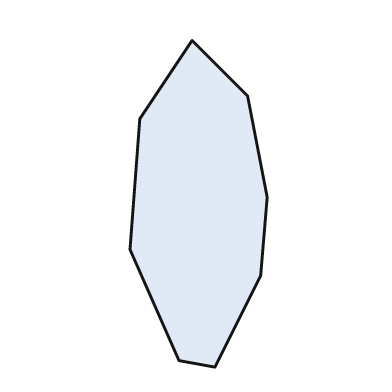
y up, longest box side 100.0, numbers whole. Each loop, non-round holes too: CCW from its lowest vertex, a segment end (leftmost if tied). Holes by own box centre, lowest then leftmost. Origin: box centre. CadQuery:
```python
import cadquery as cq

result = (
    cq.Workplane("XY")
    .moveTo(5.0, -50.0)
    .lineTo(19.0, -22.0)
    .lineTo(21.0, 2.0)
    .lineTo(15.0, 33.0)
    .lineTo(-2.0, 50.0)
    .lineTo(-18.0, 26.0)
    .lineTo(-21.0, -14.0)
    .lineTo(-6.0, -48.0)
    .close()
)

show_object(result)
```